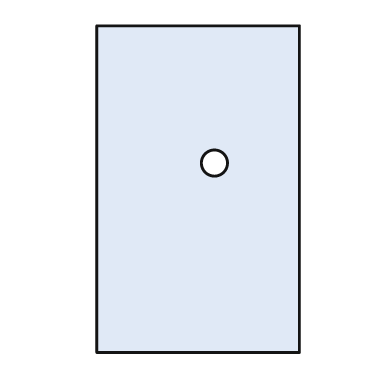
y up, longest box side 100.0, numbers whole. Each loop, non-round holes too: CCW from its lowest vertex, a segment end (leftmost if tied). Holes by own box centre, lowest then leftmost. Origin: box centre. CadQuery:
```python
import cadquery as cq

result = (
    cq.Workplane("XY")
    .moveTo(-31.0, -50.0)
    .lineTo(31.0, -50.0)
    .lineTo(31.0, 50.0)
    .lineTo(-31.0, 50.0)
    .close()
    .moveTo(5.0, 8.0)
    .circle(4.0)
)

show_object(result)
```